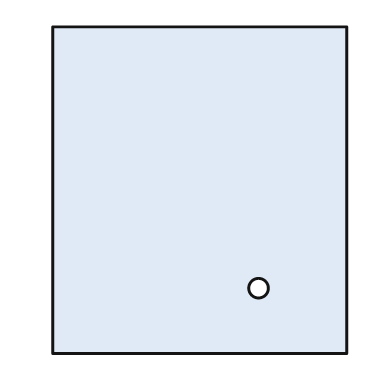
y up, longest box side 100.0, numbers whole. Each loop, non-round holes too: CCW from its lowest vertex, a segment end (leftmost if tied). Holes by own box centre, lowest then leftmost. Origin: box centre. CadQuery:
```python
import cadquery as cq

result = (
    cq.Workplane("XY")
    .moveTo(-45.0, -50.0)
    .lineTo(45.0, -50.0)
    .lineTo(45.0, 50.0)
    .lineTo(-45.0, 50.0)
    .close()
    .moveTo(18.0, -30.0)
    .circle(3.0)
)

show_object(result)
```